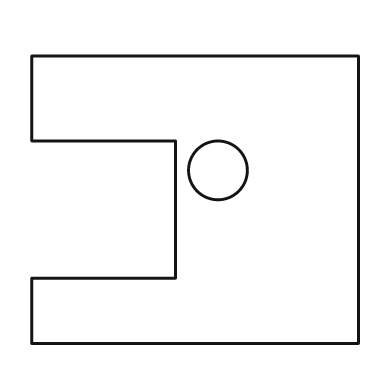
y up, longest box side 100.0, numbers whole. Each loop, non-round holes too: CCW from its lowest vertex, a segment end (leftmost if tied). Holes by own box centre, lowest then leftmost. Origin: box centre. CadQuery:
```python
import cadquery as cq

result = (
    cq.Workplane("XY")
    .moveTo(-50.0, -44.0)
    .lineTo(50.0, -44.0)
    .lineTo(50.0, 44.0)
    .lineTo(-50.0, 44.0)
    .lineTo(-50.0, 18.0)
    .lineTo(-6.0, 18.0)
    .lineTo(-6.0, -24.0)
    .lineTo(-50.0, -24.0)
    .close()
    .moveTo(7.0, 9.0)
    .circle(9.0)
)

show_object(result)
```